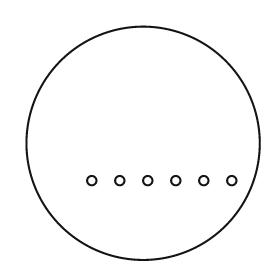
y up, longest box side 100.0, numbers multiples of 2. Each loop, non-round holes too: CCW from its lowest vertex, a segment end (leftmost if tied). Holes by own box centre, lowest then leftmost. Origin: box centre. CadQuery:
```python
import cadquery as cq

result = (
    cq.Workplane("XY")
    .moveTo(0.0, 0.0)
    .circle(50.0)
    .moveTo(-22.0, -16.0)
    .circle(2.0)
    .moveTo(-10.0, -16.0)
    .circle(2.0)
    .moveTo(2.0, -16.0)
    .circle(2.0)
    .moveTo(14.0, -16.0)
    .circle(2.0)
    .moveTo(26.0, -16.0)
    .circle(2.0)
    .moveTo(38.0, -16.0)
    .circle(2.0)
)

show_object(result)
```